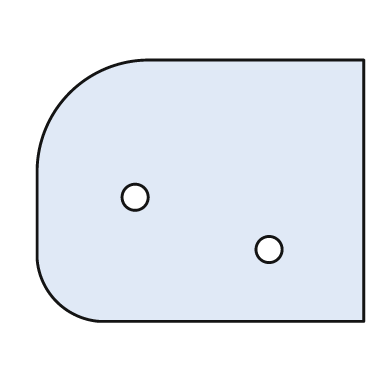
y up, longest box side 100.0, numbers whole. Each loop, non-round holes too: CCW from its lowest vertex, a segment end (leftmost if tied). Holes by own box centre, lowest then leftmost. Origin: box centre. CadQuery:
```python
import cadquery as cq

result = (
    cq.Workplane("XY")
    .moveTo(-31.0, -40.0)
    .lineTo(50.0, -40.0)
    .lineTo(50.0, 40.0)
    .lineTo(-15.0, 40.0)
    .threePointArc((-40.0, 30.0), (-50.0, 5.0))
    .lineTo(-50.0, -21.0)
    .threePointArc((-44.0, -34.0), (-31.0, -40.0))
    .close()
    .moveTo(21.0, -18.0)
    .circle(4.0)
    .moveTo(-20.0, -2.0)
    .circle(4.0)
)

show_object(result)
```